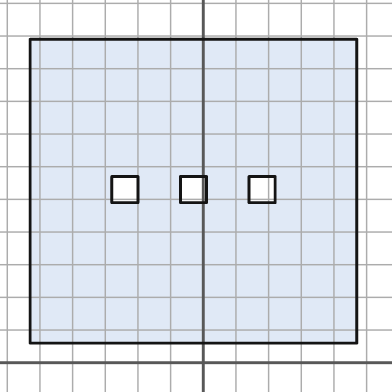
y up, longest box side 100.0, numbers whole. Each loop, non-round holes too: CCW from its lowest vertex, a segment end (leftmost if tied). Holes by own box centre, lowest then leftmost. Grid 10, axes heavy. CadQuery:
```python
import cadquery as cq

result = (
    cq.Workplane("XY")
    .moveTo(-53.0, 6.0)
    .lineTo(47.0, 6.0)
    .lineTo(47.0, 99.0)
    .lineTo(-53.0, 99.0)
    .close()
    .moveTo(-28.0, 49.0)
    .lineTo(-20.0, 49.0)
    .lineTo(-20.0, 57.0)
    .lineTo(-28.0, 57.0)
    .close()
    .moveTo(-7.0, 49.0)
    .lineTo(1.0, 49.0)
    .lineTo(1.0, 57.0)
    .lineTo(-7.0, 57.0)
    .close()
    .moveTo(14.0, 49.0)
    .lineTo(22.0, 49.0)
    .lineTo(22.0, 57.0)
    .lineTo(14.0, 57.0)
    .close()
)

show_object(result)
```